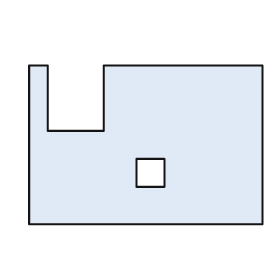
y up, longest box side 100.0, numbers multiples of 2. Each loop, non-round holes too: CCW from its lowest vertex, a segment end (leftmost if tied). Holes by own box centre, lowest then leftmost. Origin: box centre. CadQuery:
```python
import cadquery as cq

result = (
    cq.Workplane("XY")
    .moveTo(-50.0, -34.0)
    .lineTo(50.0, -34.0)
    .lineTo(50.0, 34.0)
    .lineTo(-18.0, 34.0)
    .lineTo(-18.0, 6.0)
    .lineTo(-42.0, 6.0)
    .lineTo(-42.0, 34.0)
    .lineTo(-50.0, 34.0)
    .close()
    .moveTo(-4.0, -18.0)
    .lineTo(8.0, -18.0)
    .lineTo(8.0, -6.0)
    .lineTo(-4.0, -6.0)
    .close()
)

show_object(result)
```